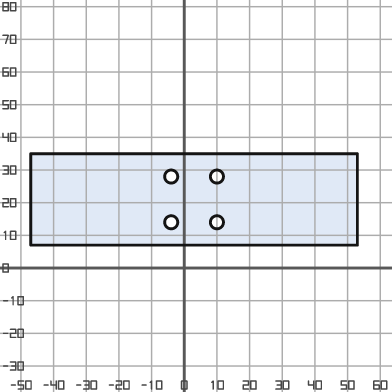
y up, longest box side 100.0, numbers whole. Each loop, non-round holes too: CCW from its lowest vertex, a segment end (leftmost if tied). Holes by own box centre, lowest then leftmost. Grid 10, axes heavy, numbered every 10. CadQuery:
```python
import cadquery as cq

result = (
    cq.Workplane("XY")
    .moveTo(-47.0, 7.0)
    .lineTo(53.0, 7.0)
    .lineTo(53.0, 35.0)
    .lineTo(-47.0, 35.0)
    .close()
    .moveTo(-4.0, 14.0)
    .circle(2.0)
    .moveTo(10.0, 14.0)
    .circle(2.0)
    .moveTo(-4.0, 28.0)
    .circle(2.0)
    .moveTo(10.0, 28.0)
    .circle(2.0)
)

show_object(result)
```